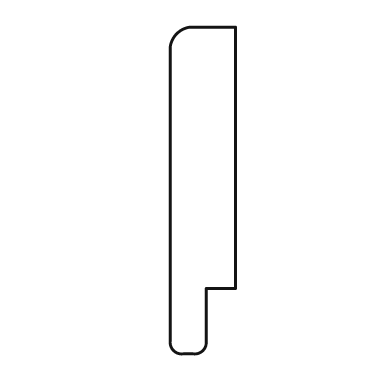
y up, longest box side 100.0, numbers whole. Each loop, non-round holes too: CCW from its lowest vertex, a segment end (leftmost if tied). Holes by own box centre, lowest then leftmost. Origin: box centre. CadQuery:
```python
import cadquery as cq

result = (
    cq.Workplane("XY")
    .moveTo(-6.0, -50.0)
    .lineTo(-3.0, -50.0)
    .threePointArc((0.0, -49.0), (1.0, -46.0))
    .lineTo(1.0, -30.0)
    .lineTo(10.0, -30.0)
    .lineTo(10.0, 50.0)
    .lineTo(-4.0, 50.0)
    .threePointArc((-8.0, 48.0), (-10.0, 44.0))
    .lineTo(-10.0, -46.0)
    .threePointArc((-9.0, -49.0), (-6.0, -50.0))
    .close()
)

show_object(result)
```